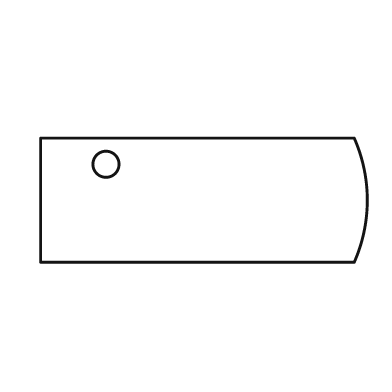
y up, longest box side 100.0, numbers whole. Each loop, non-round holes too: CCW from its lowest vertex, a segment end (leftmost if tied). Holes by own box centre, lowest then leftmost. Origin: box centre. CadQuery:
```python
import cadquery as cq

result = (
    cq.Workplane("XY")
    .moveTo(-50.0, -19.0)
    .lineTo(46.0, -19.0)
    .threePointArc((50.0, 0.0), (46.0, 19.0))
    .lineTo(-50.0, 19.0)
    .close()
    .moveTo(-30.0, 11.0)
    .circle(4.0)
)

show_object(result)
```